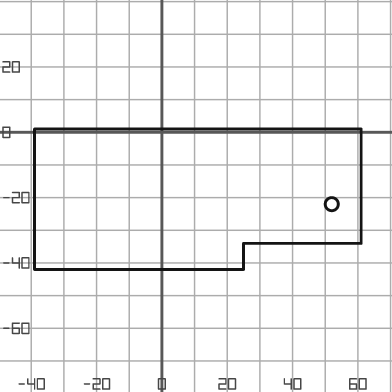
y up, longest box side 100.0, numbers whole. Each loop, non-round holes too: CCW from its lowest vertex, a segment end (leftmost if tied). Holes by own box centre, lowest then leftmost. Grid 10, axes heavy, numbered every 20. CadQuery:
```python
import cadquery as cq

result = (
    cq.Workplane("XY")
    .moveTo(-39.0, -42.0)
    .lineTo(25.0, -42.0)
    .lineTo(25.0, -34.0)
    .lineTo(61.0, -34.0)
    .lineTo(61.0, 1.0)
    .lineTo(-39.0, 1.0)
    .close()
    .moveTo(52.0, -22.0)
    .circle(2.0)
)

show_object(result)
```